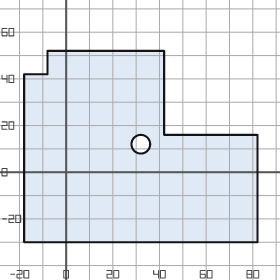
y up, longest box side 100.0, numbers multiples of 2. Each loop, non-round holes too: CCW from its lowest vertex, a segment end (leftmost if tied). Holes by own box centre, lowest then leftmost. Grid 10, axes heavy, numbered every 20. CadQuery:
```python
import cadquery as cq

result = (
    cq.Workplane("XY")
    .moveTo(-18.0, -30.0)
    .lineTo(82.0, -30.0)
    .lineTo(82.0, 16.0)
    .lineTo(42.0, 16.0)
    .lineTo(42.0, 52.0)
    .lineTo(-8.0, 52.0)
    .lineTo(-8.0, 42.0)
    .lineTo(-18.0, 42.0)
    .close()
    .moveTo(32.0, 12.0)
    .circle(4.0)
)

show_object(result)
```